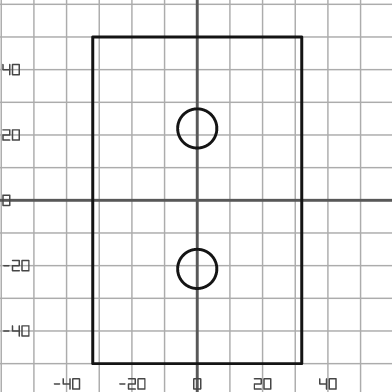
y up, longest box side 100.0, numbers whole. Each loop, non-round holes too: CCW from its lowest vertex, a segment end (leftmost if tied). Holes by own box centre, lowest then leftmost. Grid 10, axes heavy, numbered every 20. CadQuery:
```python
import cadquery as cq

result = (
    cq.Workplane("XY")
    .moveTo(-32.0, -50.0)
    .lineTo(32.0, -50.0)
    .lineTo(32.0, 50.0)
    .lineTo(-32.0, 50.0)
    .close()
    .moveTo(0.0, -21.0)
    .circle(6.0)
    .moveTo(0.0, 22.0)
    .circle(6.0)
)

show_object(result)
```